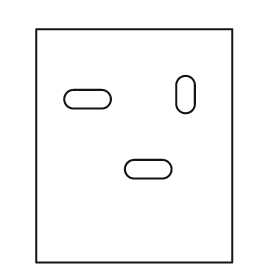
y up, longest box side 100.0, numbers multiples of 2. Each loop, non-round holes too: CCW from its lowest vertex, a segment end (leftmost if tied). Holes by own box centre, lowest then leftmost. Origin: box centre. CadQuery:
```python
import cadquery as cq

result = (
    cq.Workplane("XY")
    .moveTo(-42.0, -50.0)
    .lineTo(42.0, -50.0)
    .lineTo(42.0, 50.0)
    .lineTo(-42.0, 50.0)
    .close()
    .moveTo(0.0, -14.0)
    .lineTo(12.0, -14.0)
    .threePointArc((16.0, -10.0), (12.0, -6.0))
    .lineTo(0.0, -6.0)
    .threePointArc((-4.0, -10.0), (0.0, -14.0))
    .close()
    .moveTo(-26.0, 16.0)
    .lineTo(-14.0, 16.0)
    .threePointArc((-10.0, 20.0), (-14.0, 24.0))
    .lineTo(-26.0, 24.0)
    .threePointArc((-30.0, 20.0), (-26.0, 16.0))
    .close()
    .moveTo(18.0, 18.0)
    .threePointArc((22.0, 14.0), (26.0, 18.0))
    .lineTo(26.0, 26.0)
    .threePointArc((22.0, 30.0), (18.0, 26.0))
    .close()
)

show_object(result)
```